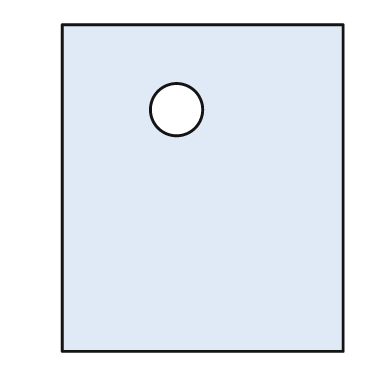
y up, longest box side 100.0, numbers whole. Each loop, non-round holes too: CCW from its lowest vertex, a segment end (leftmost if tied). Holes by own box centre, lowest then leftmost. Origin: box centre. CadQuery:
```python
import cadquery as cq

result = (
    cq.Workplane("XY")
    .moveTo(-43.0, -50.0)
    .lineTo(43.0, -50.0)
    .lineTo(43.0, 50.0)
    .lineTo(-43.0, 50.0)
    .close()
    .moveTo(-8.0, 24.0)
    .circle(8.0)
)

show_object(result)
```